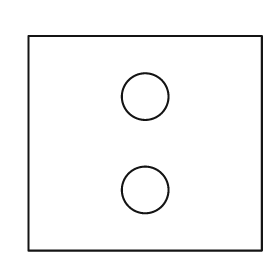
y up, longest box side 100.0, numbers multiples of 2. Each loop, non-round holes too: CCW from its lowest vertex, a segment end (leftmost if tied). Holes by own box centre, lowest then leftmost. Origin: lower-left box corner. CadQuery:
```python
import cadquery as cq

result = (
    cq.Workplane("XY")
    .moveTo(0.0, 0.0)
    .lineTo(100.0, 0.0)
    .lineTo(100.0, 92.0)
    .lineTo(0.0, 92.0)
    .close()
    .moveTo(50.0, 26.0)
    .circle(10.0)
    .moveTo(50.0, 66.0)
    .circle(10.0)
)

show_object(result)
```